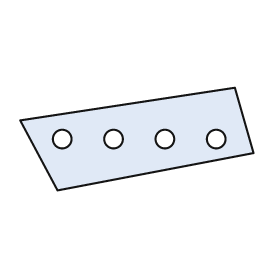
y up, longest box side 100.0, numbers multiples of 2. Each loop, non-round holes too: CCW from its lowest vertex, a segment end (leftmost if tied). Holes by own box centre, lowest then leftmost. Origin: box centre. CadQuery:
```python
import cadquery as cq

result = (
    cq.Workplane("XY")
    .moveTo(-34.0, -22.0)
    .lineTo(50.0, -6.0)
    .lineTo(42.0, 22.0)
    .lineTo(-50.0, 8.0)
    .close()
    .moveTo(-32.0, 0.0)
    .circle(4.0)
    .moveTo(-10.0, 0.0)
    .circle(4.0)
    .moveTo(12.0, 0.0)
    .circle(4.0)
    .moveTo(34.0, 0.0)
    .circle(4.0)
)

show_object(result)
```